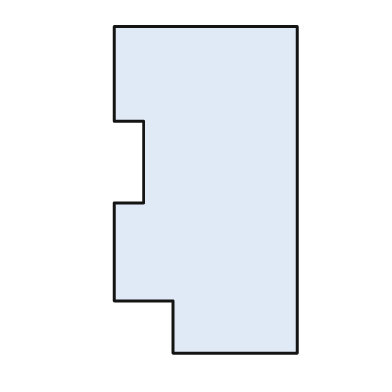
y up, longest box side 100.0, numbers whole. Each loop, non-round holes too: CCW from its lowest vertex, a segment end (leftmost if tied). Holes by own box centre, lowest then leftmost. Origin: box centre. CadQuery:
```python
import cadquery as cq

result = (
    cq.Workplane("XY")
    .moveTo(-10.0, -50.0)
    .lineTo(28.0, -50.0)
    .lineTo(28.0, 50.0)
    .lineTo(-28.0, 50.0)
    .lineTo(-28.0, 21.0)
    .lineTo(-19.0, 21.0)
    .lineTo(-19.0, -4.0)
    .lineTo(-28.0, -4.0)
    .lineTo(-28.0, -34.0)
    .lineTo(-10.0, -34.0)
    .close()
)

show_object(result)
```